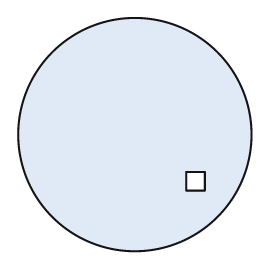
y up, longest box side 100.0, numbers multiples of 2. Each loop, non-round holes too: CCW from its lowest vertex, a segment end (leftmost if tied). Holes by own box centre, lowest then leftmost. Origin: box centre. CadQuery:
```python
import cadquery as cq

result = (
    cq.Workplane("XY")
    .moveTo(0.0, 0.0)
    .circle(50.0)
    .moveTo(22.0, -24.0)
    .lineTo(30.0, -24.0)
    .lineTo(30.0, -16.0)
    .lineTo(22.0, -16.0)
    .close()
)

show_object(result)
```